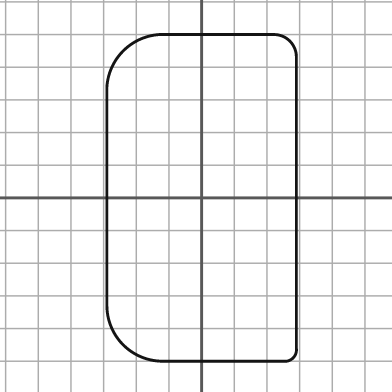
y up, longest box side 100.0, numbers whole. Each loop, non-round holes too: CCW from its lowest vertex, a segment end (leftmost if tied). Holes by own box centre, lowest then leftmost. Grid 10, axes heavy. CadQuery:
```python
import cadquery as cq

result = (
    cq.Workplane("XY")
    .moveTo(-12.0, -50.0)
    .lineTo(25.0, -50.0)
    .threePointArc((28.0, -49.0), (29.0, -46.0))
    .lineTo(29.0, 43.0)
    .threePointArc((27.0, 48.0), (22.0, 50.0))
    .lineTo(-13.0, 50.0)
    .threePointArc((-24.0, 45.0), (-29.0, 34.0))
    .lineTo(-29.0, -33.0)
    .threePointArc((-24.0, -45.0), (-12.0, -50.0))
    .close()
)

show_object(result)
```